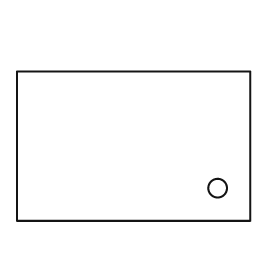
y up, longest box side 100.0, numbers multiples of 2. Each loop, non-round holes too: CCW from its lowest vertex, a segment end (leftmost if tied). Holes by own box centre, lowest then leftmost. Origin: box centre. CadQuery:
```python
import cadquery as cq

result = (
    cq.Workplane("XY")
    .moveTo(-50.0, -32.0)
    .lineTo(50.0, -32.0)
    .lineTo(50.0, 32.0)
    .lineTo(-50.0, 32.0)
    .close()
    .moveTo(36.0, -18.0)
    .circle(4.0)
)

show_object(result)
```